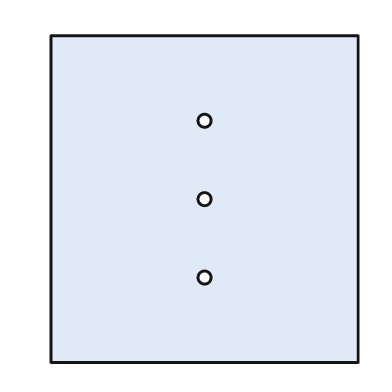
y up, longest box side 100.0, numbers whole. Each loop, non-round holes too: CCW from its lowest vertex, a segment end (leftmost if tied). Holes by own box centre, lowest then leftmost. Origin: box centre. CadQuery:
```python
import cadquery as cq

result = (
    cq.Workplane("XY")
    .moveTo(-47.0, -50.0)
    .lineTo(47.0, -50.0)
    .lineTo(47.0, 50.0)
    .lineTo(-47.0, 50.0)
    .close()
    .moveTo(0.0, -24.0)
    .circle(2.0)
    .moveTo(0.0, 0.0)
    .circle(2.0)
    .moveTo(0.0, 24.0)
    .circle(2.0)
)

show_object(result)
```